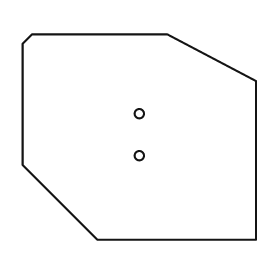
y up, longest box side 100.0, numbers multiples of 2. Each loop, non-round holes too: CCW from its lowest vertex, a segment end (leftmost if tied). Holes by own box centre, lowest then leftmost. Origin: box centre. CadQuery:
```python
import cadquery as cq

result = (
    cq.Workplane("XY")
    .moveTo(-18.0, -44.0)
    .lineTo(50.0, -44.0)
    .lineTo(50.0, 24.0)
    .lineTo(12.0, 44.0)
    .lineTo(-46.0, 44.0)
    .lineTo(-50.0, 40.0)
    .lineTo(-50.0, -12.0)
    .close()
    .moveTo(0.0, -8.0)
    .circle(2.0)
    .moveTo(0.0, 10.0)
    .circle(2.0)
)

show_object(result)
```